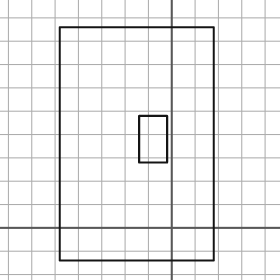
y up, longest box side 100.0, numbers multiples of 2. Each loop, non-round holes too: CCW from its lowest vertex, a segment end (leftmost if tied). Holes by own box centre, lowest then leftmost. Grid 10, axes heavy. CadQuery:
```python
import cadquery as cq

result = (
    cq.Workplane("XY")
    .moveTo(-48.0, -14.0)
    .lineTo(18.0, -14.0)
    .lineTo(18.0, 86.0)
    .lineTo(-48.0, 86.0)
    .close()
    .moveTo(-14.0, 28.0)
    .lineTo(-2.0, 28.0)
    .lineTo(-2.0, 48.0)
    .lineTo(-14.0, 48.0)
    .close()
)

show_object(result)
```